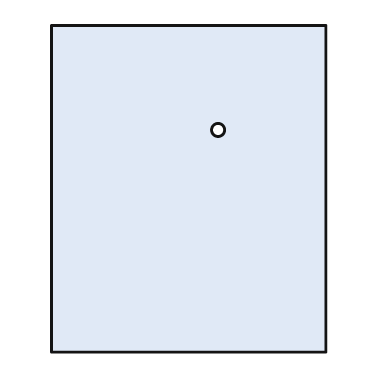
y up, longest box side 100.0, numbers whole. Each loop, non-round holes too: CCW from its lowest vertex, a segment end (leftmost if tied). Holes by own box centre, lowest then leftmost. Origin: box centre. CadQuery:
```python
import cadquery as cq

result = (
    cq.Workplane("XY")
    .moveTo(-42.0, -50.0)
    .lineTo(42.0, -50.0)
    .lineTo(42.0, 50.0)
    .lineTo(-42.0, 50.0)
    .close()
    .moveTo(9.0, 18.0)
    .circle(2.0)
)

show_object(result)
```